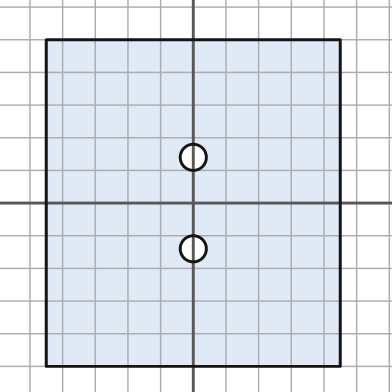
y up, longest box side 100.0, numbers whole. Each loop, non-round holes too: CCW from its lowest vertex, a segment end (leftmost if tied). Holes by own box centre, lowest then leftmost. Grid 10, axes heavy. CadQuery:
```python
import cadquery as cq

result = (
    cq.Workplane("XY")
    .moveTo(-45.0, -50.0)
    .lineTo(45.0, -50.0)
    .lineTo(45.0, 50.0)
    .lineTo(-45.0, 50.0)
    .close()
    .moveTo(0.0, -14.0)
    .circle(4.0)
    .moveTo(0.0, 14.0)
    .circle(4.0)
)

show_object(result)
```